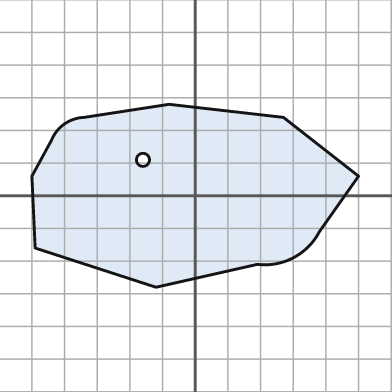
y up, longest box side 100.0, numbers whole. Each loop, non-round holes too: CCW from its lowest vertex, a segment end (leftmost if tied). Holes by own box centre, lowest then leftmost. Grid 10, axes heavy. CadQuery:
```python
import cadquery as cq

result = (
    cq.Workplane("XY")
    .moveTo(-12.0, -28.0)
    .lineTo(19.0, -21.0)
    .threePointArc((30.0, -19.0), (38.0, -11.0))
    .lineTo(50.0, 6.0)
    .lineTo(27.0, 24.0)
    .lineTo(-8.0, 28.0)
    .lineTo(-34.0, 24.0)
    .threePointArc((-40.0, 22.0), (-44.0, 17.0))
    .lineTo(-50.0, 6.0)
    .lineTo(-49.0, -16.0)
    .close()
    .moveTo(-16.0, 11.0)
    .circle(2.0)
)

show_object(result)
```